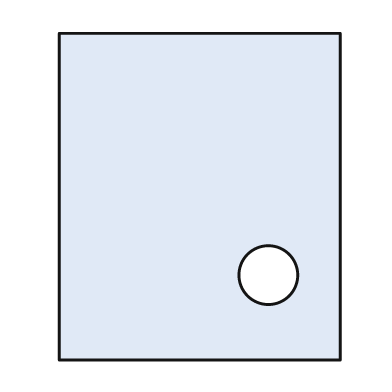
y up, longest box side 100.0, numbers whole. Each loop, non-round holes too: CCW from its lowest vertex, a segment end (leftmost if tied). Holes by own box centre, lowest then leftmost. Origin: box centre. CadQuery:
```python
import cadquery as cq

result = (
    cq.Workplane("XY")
    .moveTo(-43.0, -50.0)
    .lineTo(43.0, -50.0)
    .lineTo(43.0, 50.0)
    .lineTo(-43.0, 50.0)
    .close()
    .moveTo(21.0, -24.0)
    .circle(9.0)
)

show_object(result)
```